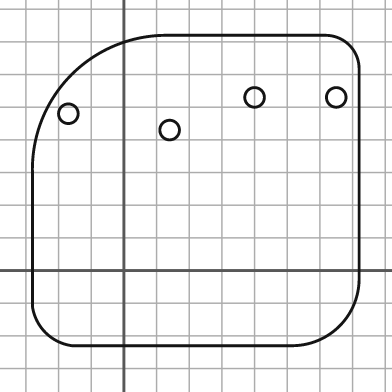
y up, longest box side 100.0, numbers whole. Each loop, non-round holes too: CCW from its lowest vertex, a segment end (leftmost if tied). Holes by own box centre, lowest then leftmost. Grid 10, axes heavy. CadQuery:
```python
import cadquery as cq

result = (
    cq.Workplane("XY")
    .moveTo(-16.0, -23.0)
    .lineTo(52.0, -23.0)
    .threePointArc((66.0, -17.0), (72.0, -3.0))
    .lineTo(72.0, 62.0)
    .threePointArc((69.0, 69.0), (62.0, 72.0))
    .lineTo(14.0, 72.0)
    .threePointArc((-16.0, 60.0), (-28.0, 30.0))
    .lineTo(-28.0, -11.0)
    .threePointArc((-24.0, -19.0), (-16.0, -23.0))
    .close()
    .moveTo(14.0, 43.0)
    .circle(3.0)
    .moveTo(-17.0, 48.0)
    .circle(3.0)
    .moveTo(40.0, 53.0)
    .circle(3.0)
    .moveTo(65.0, 53.0)
    .circle(3.0)
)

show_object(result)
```